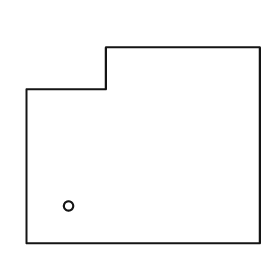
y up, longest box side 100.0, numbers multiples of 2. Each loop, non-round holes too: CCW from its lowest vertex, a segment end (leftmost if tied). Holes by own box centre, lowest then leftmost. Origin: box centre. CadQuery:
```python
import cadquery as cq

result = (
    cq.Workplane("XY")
    .moveTo(-50.0, -42.0)
    .lineTo(50.0, -42.0)
    .lineTo(50.0, 42.0)
    .lineTo(-16.0, 42.0)
    .lineTo(-16.0, 24.0)
    .lineTo(-50.0, 24.0)
    .close()
    .moveTo(-32.0, -26.0)
    .circle(2.0)
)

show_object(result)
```